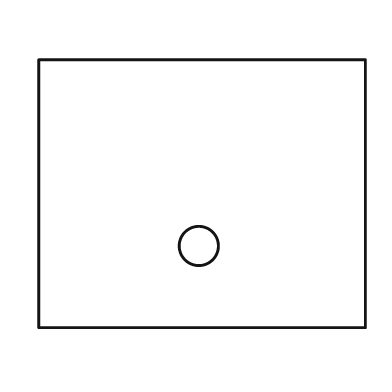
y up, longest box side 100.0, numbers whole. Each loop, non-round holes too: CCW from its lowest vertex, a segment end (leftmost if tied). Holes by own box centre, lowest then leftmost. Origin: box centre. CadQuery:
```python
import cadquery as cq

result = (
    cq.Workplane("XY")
    .moveTo(-50.0, -41.0)
    .lineTo(50.0, -41.0)
    .lineTo(50.0, 41.0)
    .lineTo(-50.0, 41.0)
    .close()
    .moveTo(-1.0, -16.0)
    .circle(6.0)
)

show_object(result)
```